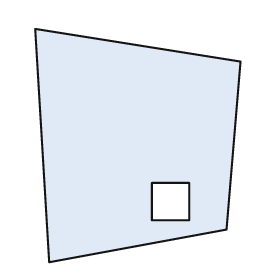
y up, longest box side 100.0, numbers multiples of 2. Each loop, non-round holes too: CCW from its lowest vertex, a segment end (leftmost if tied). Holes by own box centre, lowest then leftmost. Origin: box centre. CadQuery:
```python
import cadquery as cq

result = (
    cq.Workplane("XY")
    .moveTo(-38.0, -50.0)
    .lineTo(38.0, -36.0)
    .lineTo(44.0, 36.0)
    .lineTo(-44.0, 50.0)
    .close()
    .moveTo(6.0, -32.0)
    .lineTo(22.0, -32.0)
    .lineTo(22.0, -16.0)
    .lineTo(6.0, -16.0)
    .close()
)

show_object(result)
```